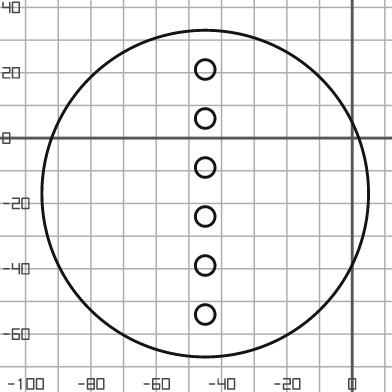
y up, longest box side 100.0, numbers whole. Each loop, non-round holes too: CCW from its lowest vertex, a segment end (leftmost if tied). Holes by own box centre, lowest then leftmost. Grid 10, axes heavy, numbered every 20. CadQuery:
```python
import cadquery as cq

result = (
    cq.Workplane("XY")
    .moveTo(-45.0, -17.0)
    .circle(50.0)
    .moveTo(-45.0, -54.0)
    .circle(3.0)
    .moveTo(-45.0, -39.0)
    .circle(3.0)
    .moveTo(-45.0, -24.0)
    .circle(3.0)
    .moveTo(-45.0, -9.0)
    .circle(3.0)
    .moveTo(-45.0, 6.0)
    .circle(3.0)
    .moveTo(-45.0, 21.0)
    .circle(3.0)
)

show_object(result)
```